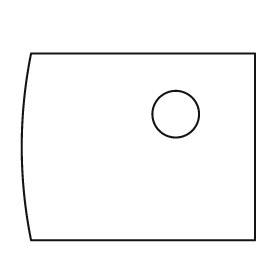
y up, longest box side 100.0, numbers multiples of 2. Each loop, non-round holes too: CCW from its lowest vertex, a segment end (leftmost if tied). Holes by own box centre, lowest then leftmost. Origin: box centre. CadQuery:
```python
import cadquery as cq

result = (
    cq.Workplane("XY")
    .moveTo(-46.0, -40.0)
    .lineTo(50.0, -40.0)
    .lineTo(50.0, 40.0)
    .lineTo(-46.0, 40.0)
    .threePointArc((-50.0, 0.0), (-46.0, -40.0))
    .close()
    .moveTo(16.0, 14.0)
    .circle(10.0)
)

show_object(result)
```